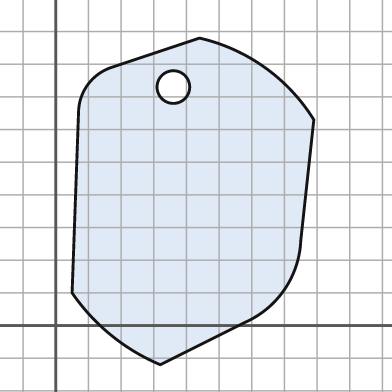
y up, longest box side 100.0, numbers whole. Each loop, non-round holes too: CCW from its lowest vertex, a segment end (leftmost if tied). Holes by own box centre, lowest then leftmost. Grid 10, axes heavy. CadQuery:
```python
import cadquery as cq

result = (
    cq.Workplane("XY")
    .moveTo(32.0, -12.0)
    .lineTo(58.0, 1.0)
    .threePointArc((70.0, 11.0), (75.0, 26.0))
    .lineTo(79.0, 63.0)
    .threePointArc((64.0, 79.0), (44.0, 88.0))
    .lineTo(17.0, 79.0)
    .threePointArc((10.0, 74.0), (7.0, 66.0))
    .lineTo(5.0, 10.0)
    .threePointArc((17.0, -3.0), (32.0, -12.0))
    .close()
    .moveTo(36.0, 73.0)
    .circle(5.0)
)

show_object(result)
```